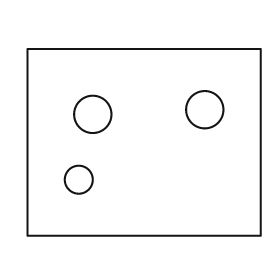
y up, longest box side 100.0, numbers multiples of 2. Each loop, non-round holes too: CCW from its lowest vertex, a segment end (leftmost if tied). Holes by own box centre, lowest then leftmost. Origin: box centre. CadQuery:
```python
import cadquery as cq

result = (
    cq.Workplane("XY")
    .moveTo(-50.0, -40.0)
    .lineTo(50.0, -40.0)
    .lineTo(50.0, 40.0)
    .lineTo(-50.0, 40.0)
    .close()
    .moveTo(-28.0, -16.0)
    .circle(6.0)
    .moveTo(-22.0, 12.0)
    .circle(8.0)
    .moveTo(26.0, 14.0)
    .circle(8.0)
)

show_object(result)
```